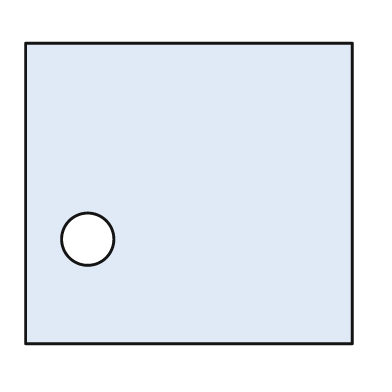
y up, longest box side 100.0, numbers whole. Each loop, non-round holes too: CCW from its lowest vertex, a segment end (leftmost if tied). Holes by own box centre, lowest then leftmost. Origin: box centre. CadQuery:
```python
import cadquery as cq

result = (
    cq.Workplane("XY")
    .moveTo(-50.0, -46.0)
    .lineTo(50.0, -46.0)
    .lineTo(50.0, 46.0)
    .lineTo(-50.0, 46.0)
    .close()
    .moveTo(-31.0, -14.0)
    .circle(8.0)
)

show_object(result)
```